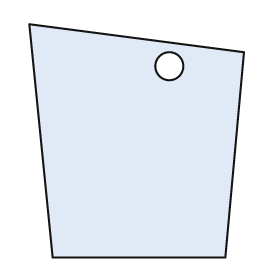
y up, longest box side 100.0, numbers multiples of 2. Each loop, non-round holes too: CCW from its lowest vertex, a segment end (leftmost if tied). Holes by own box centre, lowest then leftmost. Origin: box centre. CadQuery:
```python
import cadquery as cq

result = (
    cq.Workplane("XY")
    .moveTo(-36.0, -50.0)
    .lineTo(38.0, -50.0)
    .lineTo(46.0, 38.0)
    .lineTo(-46.0, 50.0)
    .close()
    .moveTo(14.0, 32.0)
    .circle(6.0)
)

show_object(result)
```